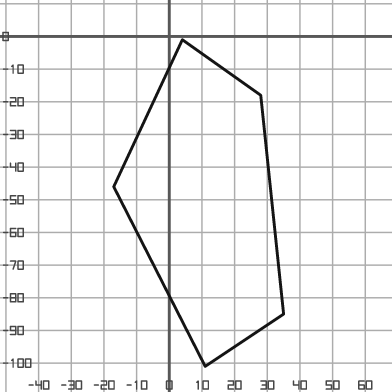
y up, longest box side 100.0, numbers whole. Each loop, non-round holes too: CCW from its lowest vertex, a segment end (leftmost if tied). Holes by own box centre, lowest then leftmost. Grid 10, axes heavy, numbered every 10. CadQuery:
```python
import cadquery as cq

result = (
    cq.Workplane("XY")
    .moveTo(11.0, -101.0)
    .lineTo(35.0, -85.0)
    .lineTo(28.0, -18.0)
    .lineTo(4.0, -1.0)
    .lineTo(-17.0, -46.0)
    .close()
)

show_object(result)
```